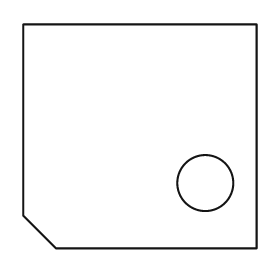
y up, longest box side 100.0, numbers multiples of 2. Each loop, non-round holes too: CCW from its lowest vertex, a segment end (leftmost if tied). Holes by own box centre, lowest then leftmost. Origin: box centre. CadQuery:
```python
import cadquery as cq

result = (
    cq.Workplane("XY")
    .moveTo(-36.0, -48.0)
    .lineTo(50.0, -48.0)
    .lineTo(50.0, 48.0)
    .lineTo(-50.0, 48.0)
    .lineTo(-50.0, -34.0)
    .close()
    .moveTo(28.0, -20.0)
    .circle(12.0)
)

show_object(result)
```